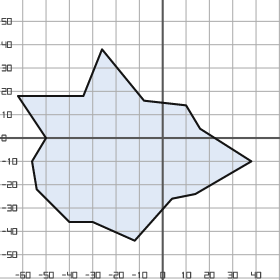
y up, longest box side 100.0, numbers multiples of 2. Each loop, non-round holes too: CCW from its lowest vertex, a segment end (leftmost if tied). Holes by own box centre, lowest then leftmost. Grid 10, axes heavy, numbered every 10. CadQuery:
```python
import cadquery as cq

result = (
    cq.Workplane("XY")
    .moveTo(-12.0, -44.0)
    .lineTo(4.0, -26.0)
    .lineTo(14.0, -24.0)
    .lineTo(38.0, -10.0)
    .lineTo(16.0, 4.0)
    .lineTo(10.0, 14.0)
    .lineTo(-8.0, 16.0)
    .lineTo(-26.0, 38.0)
    .lineTo(-34.0, 18.0)
    .lineTo(-62.0, 18.0)
    .lineTo(-50.0, 0.0)
    .lineTo(-56.0, -10.0)
    .lineTo(-54.0, -22.0)
    .lineTo(-40.0, -36.0)
    .lineTo(-30.0, -36.0)
    .close()
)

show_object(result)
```